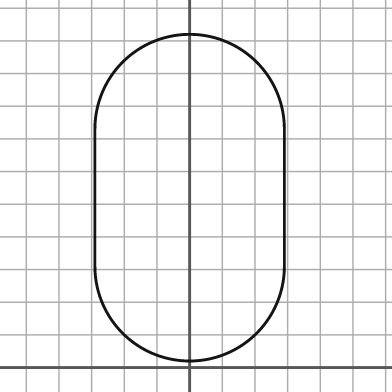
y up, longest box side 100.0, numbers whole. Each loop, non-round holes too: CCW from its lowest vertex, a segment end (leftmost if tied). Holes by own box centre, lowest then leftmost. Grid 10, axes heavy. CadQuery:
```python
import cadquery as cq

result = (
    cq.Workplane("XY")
    .moveTo(-29.0, 31.0)
    .threePointArc((0.0, 2.0), (29.0, 31.0))
    .lineTo(29.0, 73.0)
    .threePointArc((0.0, 102.0), (-29.0, 73.0))
    .close()
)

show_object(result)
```